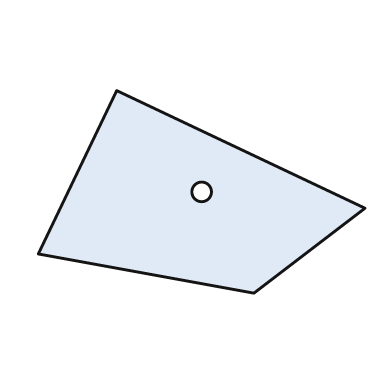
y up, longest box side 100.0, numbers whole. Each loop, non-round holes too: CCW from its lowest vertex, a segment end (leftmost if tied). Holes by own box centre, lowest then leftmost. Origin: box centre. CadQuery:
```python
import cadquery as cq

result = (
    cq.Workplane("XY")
    .moveTo(16.0, -31.0)
    .lineTo(50.0, -5.0)
    .lineTo(-26.0, 31.0)
    .lineTo(-50.0, -19.0)
    .close()
    .moveTo(0.0, 0.0)
    .circle(3.0)
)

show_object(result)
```